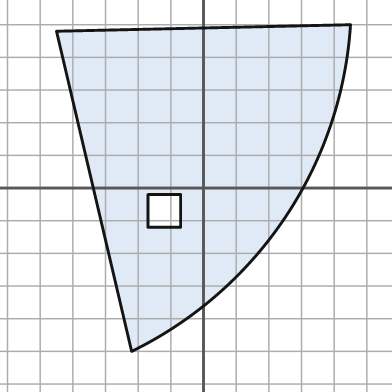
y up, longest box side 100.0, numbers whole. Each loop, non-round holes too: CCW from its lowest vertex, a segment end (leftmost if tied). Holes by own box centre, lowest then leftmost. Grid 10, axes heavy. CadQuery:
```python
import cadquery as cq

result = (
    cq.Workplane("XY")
    .moveTo(-22.0, -50.0)
    .threePointArc((25.0, -9.0), (45.0, 50.0))
    .lineTo(-45.0, 48.0)
    .close()
    .moveTo(-17.0, -12.0)
    .lineTo(-7.0, -12.0)
    .lineTo(-7.0, -2.0)
    .lineTo(-17.0, -2.0)
    .close()
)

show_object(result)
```